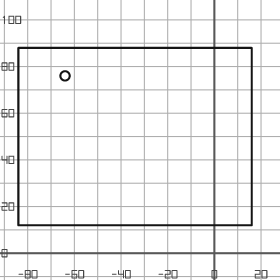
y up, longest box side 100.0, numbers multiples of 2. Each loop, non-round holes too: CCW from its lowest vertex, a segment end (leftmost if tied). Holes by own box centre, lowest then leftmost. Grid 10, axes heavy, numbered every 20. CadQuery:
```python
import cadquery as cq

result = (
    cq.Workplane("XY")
    .moveTo(-84.0, 12.0)
    .lineTo(16.0, 12.0)
    .lineTo(16.0, 88.0)
    .lineTo(-84.0, 88.0)
    .close()
    .moveTo(-64.0, 76.0)
    .circle(2.0)
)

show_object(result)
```